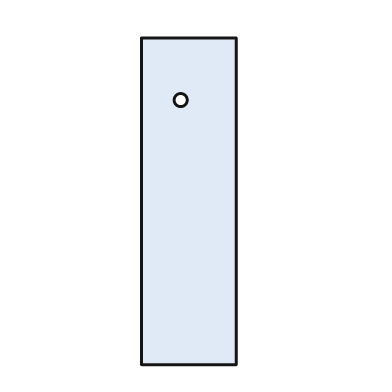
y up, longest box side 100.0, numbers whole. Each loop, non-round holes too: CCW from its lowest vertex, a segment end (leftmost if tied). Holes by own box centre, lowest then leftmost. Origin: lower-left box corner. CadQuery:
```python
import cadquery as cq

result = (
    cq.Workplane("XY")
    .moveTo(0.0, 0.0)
    .lineTo(29.0, 0.0)
    .lineTo(29.0, 100.0)
    .lineTo(0.0, 100.0)
    .close()
    .moveTo(12.0, 81.0)
    .circle(2.0)
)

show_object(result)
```